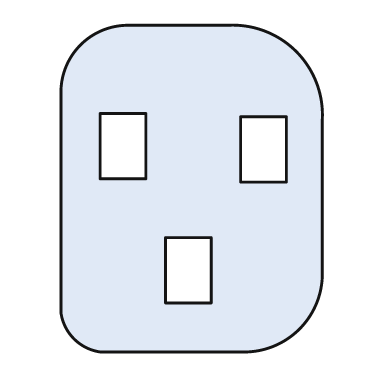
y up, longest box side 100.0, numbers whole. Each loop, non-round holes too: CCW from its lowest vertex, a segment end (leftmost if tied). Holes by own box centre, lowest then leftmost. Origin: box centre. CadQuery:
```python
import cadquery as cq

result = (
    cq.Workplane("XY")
    .moveTo(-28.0, -50.0)
    .lineTo(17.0, -50.0)
    .threePointArc((33.0, -43.0), (40.0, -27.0))
    .lineTo(40.0, 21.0)
    .threePointArc((32.0, 42.0), (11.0, 50.0))
    .lineTo(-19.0, 50.0)
    .threePointArc((-34.0, 44.0), (-40.0, 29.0))
    .lineTo(-40.0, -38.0)
    .threePointArc((-36.0, -46.0), (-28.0, -50.0))
    .close()
    .moveTo(-8.0, -35.0)
    .lineTo(6.0, -35.0)
    .lineTo(6.0, -15.0)
    .lineTo(-8.0, -15.0)
    .close()
    .moveTo(15.0, 2.0)
    .lineTo(29.0, 2.0)
    .lineTo(29.0, 22.0)
    .lineTo(15.0, 22.0)
    .close()
    .moveTo(-28.0, 3.0)
    .lineTo(-14.0, 3.0)
    .lineTo(-14.0, 23.0)
    .lineTo(-28.0, 23.0)
    .close()
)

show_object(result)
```